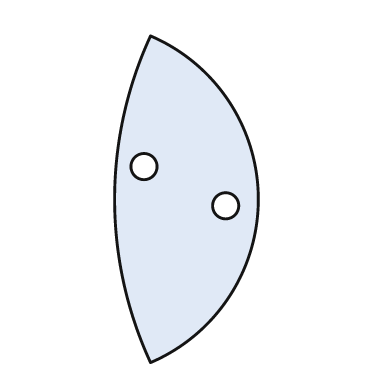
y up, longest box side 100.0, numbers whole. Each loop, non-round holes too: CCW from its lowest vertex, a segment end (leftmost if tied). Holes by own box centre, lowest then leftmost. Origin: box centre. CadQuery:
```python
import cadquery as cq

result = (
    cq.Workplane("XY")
    .moveTo(-11.0, -50.0)
    .threePointArc((22.0, 0.0), (-11.0, 50.0))
    .threePointArc((-22.0, 0.0), (-11.0, -50.0))
    .close()
    .moveTo(12.0, -2.0)
    .circle(4.0)
    .moveTo(-13.0, 10.0)
    .circle(4.0)
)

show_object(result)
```